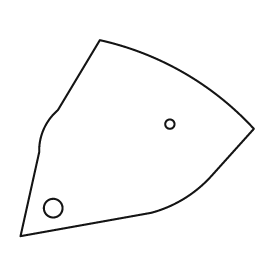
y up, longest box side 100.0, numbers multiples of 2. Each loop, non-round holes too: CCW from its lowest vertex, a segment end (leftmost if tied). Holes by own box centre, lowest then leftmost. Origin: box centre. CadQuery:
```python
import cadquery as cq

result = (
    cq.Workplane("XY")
    .moveTo(-50.0, -42.0)
    .lineTo(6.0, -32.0)
    .threePointArc((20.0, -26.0), (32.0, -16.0))
    .lineTo(50.0, 4.0)
    .threePointArc((20.0, 28.0), (-16.0, 42.0))
    .lineTo(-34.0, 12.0)
    .threePointArc((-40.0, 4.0), (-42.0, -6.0))
    .close()
    .moveTo(-36.0, -30.0)
    .circle(4.0)
    .moveTo(14.0, 6.0)
    .circle(2.0)
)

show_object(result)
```